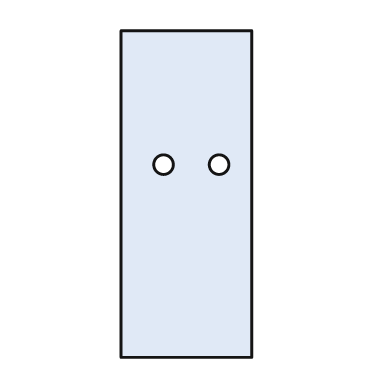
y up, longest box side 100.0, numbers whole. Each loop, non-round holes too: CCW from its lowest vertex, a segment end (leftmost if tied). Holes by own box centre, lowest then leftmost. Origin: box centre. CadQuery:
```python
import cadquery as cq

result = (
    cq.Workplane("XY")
    .moveTo(-20.0, -50.0)
    .lineTo(20.0, -50.0)
    .lineTo(20.0, 50.0)
    .lineTo(-20.0, 50.0)
    .close()
    .moveTo(-7.0, 9.0)
    .circle(3.0)
    .moveTo(10.0, 9.0)
    .circle(3.0)
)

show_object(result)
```